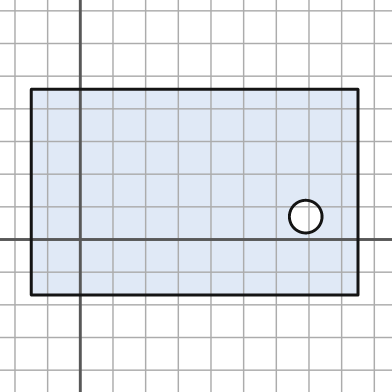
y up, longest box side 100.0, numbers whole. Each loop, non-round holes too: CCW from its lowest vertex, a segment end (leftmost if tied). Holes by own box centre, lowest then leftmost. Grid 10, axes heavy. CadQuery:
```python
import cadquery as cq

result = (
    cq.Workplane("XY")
    .moveTo(-15.0, -17.0)
    .lineTo(85.0, -17.0)
    .lineTo(85.0, 46.0)
    .lineTo(-15.0, 46.0)
    .close()
    .moveTo(69.0, 7.0)
    .circle(5.0)
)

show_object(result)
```